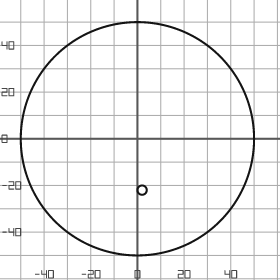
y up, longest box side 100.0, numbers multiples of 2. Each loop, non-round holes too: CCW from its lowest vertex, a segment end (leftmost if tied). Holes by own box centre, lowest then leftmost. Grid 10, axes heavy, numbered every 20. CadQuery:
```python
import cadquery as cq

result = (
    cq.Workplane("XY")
    .moveTo(0.0, 0.0)
    .circle(50.0)
    .moveTo(2.0, -22.0)
    .circle(2.0)
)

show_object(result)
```